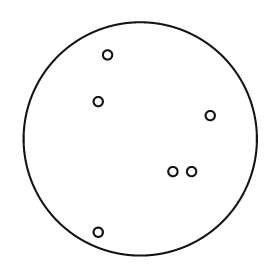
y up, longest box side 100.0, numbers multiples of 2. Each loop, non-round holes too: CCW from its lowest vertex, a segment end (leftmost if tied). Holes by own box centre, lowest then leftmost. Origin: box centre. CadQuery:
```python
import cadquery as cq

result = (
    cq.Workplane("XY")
    .moveTo(0.0, 0.0)
    .circle(50.0)
    .moveTo(-18.0, -40.0)
    .circle(2.0)
    .moveTo(14.0, -14.0)
    .circle(2.0)
    .moveTo(22.0, -14.0)
    .circle(2.0)
    .moveTo(30.0, 10.0)
    .circle(2.0)
    .moveTo(-18.0, 16.0)
    .circle(2.0)
    .moveTo(-14.0, 36.0)
    .circle(2.0)
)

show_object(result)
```